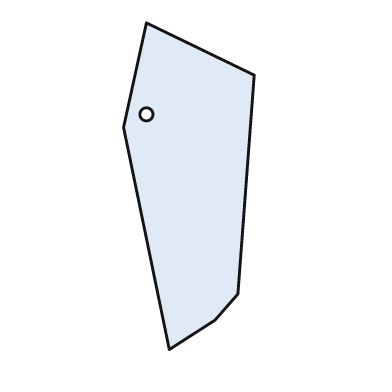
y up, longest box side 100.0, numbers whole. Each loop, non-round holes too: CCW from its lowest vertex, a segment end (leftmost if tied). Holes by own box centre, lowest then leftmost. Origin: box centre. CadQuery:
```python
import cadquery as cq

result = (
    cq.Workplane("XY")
    .moveTo(-6.0, -50.0)
    .lineTo(8.0, -41.0)
    .lineTo(15.0, -33.0)
    .lineTo(20.0, 34.0)
    .lineTo(-13.0, 50.0)
    .lineTo(-20.0, 18.0)
    .close()
    .moveTo(-13.0, 22.0)
    .circle(2.0)
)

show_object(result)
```